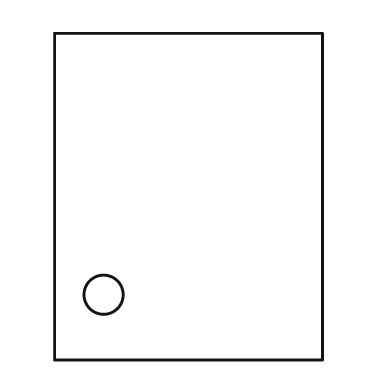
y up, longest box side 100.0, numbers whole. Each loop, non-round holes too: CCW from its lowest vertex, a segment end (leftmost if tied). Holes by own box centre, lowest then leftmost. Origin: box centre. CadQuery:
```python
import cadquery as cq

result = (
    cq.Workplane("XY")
    .moveTo(-41.0, -50.0)
    .lineTo(41.0, -50.0)
    .lineTo(41.0, 50.0)
    .lineTo(-41.0, 50.0)
    .close()
    .moveTo(-26.0, -30.0)
    .circle(6.0)
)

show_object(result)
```